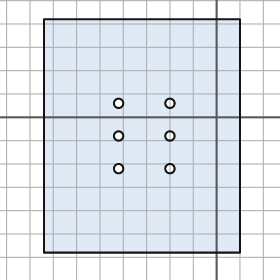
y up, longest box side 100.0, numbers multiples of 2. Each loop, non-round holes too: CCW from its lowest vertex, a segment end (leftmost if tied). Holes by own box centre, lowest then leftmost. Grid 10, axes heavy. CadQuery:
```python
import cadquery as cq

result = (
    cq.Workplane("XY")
    .moveTo(-74.0, -58.0)
    .lineTo(10.0, -58.0)
    .lineTo(10.0, 42.0)
    .lineTo(-74.0, 42.0)
    .close()
    .moveTo(-42.0, -22.0)
    .circle(2.0)
    .moveTo(-20.0, -22.0)
    .circle(2.0)
    .moveTo(-42.0, -8.0)
    .circle(2.0)
    .moveTo(-20.0, -8.0)
    .circle(2.0)
    .moveTo(-42.0, 6.0)
    .circle(2.0)
    .moveTo(-20.0, 6.0)
    .circle(2.0)
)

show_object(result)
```